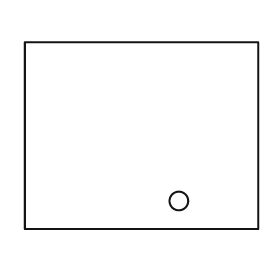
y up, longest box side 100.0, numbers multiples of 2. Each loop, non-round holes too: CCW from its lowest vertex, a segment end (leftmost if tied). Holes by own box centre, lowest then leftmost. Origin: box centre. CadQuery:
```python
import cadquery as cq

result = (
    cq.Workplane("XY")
    .moveTo(-50.0, -40.0)
    .lineTo(50.0, -40.0)
    .lineTo(50.0, 40.0)
    .lineTo(-50.0, 40.0)
    .close()
    .moveTo(16.0, -28.0)
    .circle(4.0)
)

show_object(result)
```